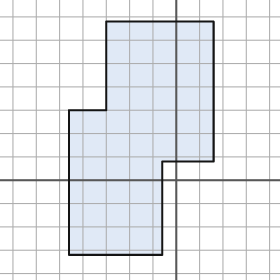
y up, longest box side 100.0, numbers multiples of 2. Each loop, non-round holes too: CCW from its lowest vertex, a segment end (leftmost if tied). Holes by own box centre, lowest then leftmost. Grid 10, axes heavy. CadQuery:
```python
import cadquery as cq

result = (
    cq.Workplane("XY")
    .moveTo(-46.0, -32.0)
    .lineTo(-6.0, -32.0)
    .lineTo(-6.0, 8.0)
    .lineTo(16.0, 8.0)
    .lineTo(16.0, 68.0)
    .lineTo(-30.0, 68.0)
    .lineTo(-30.0, 30.0)
    .lineTo(-46.0, 30.0)
    .close()
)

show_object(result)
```